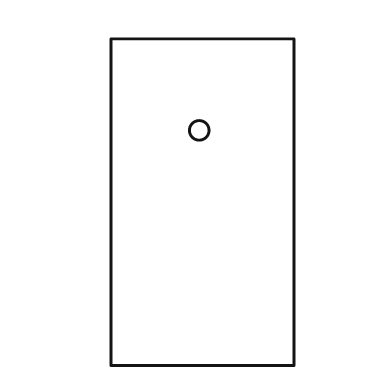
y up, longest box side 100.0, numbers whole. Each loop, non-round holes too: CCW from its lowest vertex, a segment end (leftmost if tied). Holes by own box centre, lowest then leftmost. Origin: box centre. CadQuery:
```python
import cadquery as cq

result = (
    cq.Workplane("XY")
    .moveTo(-28.0, -50.0)
    .lineTo(28.0, -50.0)
    .lineTo(28.0, 50.0)
    .lineTo(-28.0, 50.0)
    .close()
    .moveTo(-1.0, 22.0)
    .circle(3.0)
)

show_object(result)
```